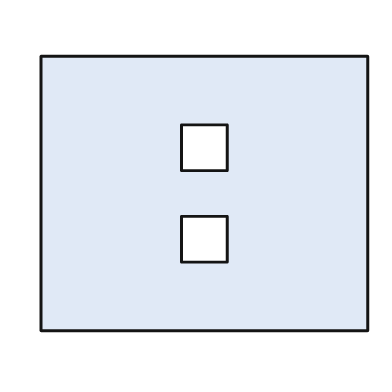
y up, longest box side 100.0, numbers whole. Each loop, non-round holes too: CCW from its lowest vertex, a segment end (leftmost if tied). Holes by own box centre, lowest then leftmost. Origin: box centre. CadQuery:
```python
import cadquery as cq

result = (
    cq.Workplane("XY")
    .moveTo(-50.0, -42.0)
    .lineTo(50.0, -42.0)
    .lineTo(50.0, 42.0)
    .lineTo(-50.0, 42.0)
    .close()
    .moveTo(-7.0, -21.0)
    .lineTo(7.0, -21.0)
    .lineTo(7.0, -7.0)
    .lineTo(-7.0, -7.0)
    .close()
    .moveTo(-7.0, 7.0)
    .lineTo(7.0, 7.0)
    .lineTo(7.0, 21.0)
    .lineTo(-7.0, 21.0)
    .close()
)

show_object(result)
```